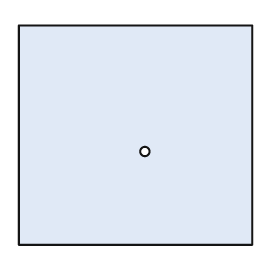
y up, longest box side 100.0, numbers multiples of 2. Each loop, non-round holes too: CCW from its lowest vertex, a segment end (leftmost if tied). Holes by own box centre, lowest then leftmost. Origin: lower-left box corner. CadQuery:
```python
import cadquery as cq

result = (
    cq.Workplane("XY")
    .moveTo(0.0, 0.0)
    .lineTo(100.0, 0.0)
    .lineTo(100.0, 94.0)
    .lineTo(0.0, 94.0)
    .close()
    .moveTo(54.0, 40.0)
    .circle(2.0)
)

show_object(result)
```